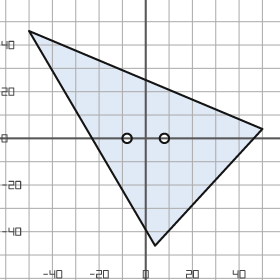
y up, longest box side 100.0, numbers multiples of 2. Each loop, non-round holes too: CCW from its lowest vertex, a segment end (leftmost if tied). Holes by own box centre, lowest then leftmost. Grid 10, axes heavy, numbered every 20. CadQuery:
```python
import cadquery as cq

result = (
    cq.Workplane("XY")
    .moveTo(4.0, -46.0)
    .lineTo(50.0, 4.0)
    .lineTo(-50.0, 46.0)
    .close()
    .moveTo(-8.0, 0.0)
    .circle(2.0)
    .moveTo(8.0, 0.0)
    .circle(2.0)
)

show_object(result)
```